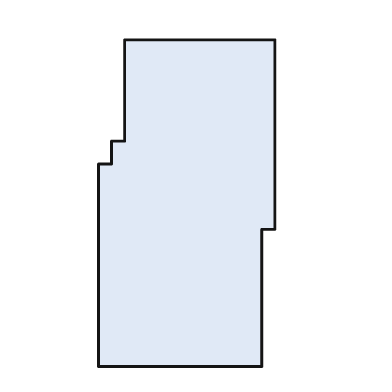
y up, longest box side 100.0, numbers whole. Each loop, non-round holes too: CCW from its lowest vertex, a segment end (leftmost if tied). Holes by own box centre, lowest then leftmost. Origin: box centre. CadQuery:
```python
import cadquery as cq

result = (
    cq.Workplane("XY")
    .moveTo(-27.0, -50.0)
    .lineTo(23.0, -50.0)
    .lineTo(23.0, -8.0)
    .lineTo(27.0, -8.0)
    .lineTo(27.0, 50.0)
    .lineTo(-19.0, 50.0)
    .lineTo(-19.0, 19.0)
    .lineTo(-23.0, 19.0)
    .lineTo(-23.0, 12.0)
    .lineTo(-27.0, 12.0)
    .close()
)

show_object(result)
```